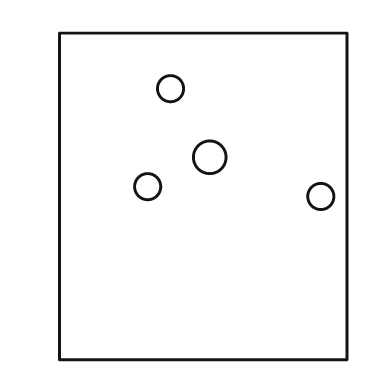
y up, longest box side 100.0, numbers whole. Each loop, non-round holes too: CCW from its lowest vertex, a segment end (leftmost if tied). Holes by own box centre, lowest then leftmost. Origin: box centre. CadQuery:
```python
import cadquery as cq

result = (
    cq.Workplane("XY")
    .moveTo(-44.0, -50.0)
    .lineTo(44.0, -50.0)
    .lineTo(44.0, 50.0)
    .lineTo(-44.0, 50.0)
    .close()
    .moveTo(36.0, 0.0)
    .circle(4.0)
    .moveTo(-17.0, 3.0)
    .circle(4.0)
    .moveTo(2.0, 12.0)
    .circle(5.0)
    .moveTo(-10.0, 33.0)
    .circle(4.0)
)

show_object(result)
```